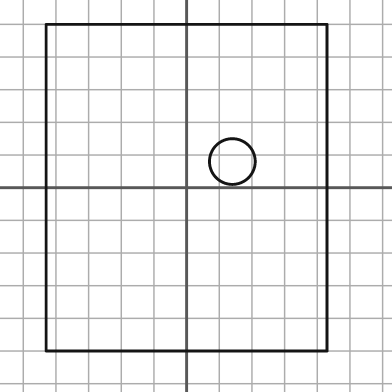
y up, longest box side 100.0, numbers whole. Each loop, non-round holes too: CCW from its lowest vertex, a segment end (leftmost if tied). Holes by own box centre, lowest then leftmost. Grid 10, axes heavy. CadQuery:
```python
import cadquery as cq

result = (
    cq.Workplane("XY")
    .moveTo(-43.0, -50.0)
    .lineTo(43.0, -50.0)
    .lineTo(43.0, 50.0)
    .lineTo(-43.0, 50.0)
    .close()
    .moveTo(14.0, 8.0)
    .circle(7.0)
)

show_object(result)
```